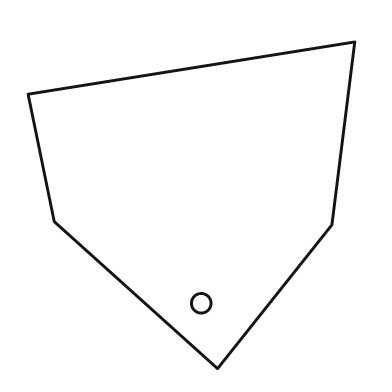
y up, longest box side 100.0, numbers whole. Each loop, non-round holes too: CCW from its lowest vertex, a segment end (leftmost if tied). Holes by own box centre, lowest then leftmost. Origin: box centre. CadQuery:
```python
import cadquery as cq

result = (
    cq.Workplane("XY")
    .moveTo(8.0, -50.0)
    .lineTo(43.0, -6.0)
    .lineTo(50.0, 50.0)
    .lineTo(-50.0, 34.0)
    .lineTo(-42.0, -5.0)
    .close()
    .moveTo(3.0, -30.0)
    .circle(3.0)
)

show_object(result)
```